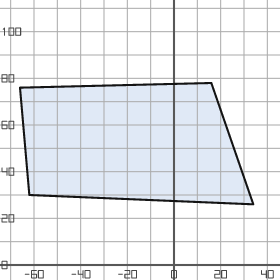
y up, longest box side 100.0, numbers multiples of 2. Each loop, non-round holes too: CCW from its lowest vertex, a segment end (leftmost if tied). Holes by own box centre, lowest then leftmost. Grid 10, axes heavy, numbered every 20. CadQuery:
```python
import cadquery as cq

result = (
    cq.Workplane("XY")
    .moveTo(34.0, 26.0)
    .lineTo(16.0, 78.0)
    .lineTo(-66.0, 76.0)
    .lineTo(-62.0, 30.0)
    .close()
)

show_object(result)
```